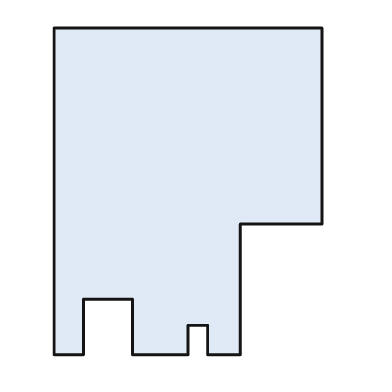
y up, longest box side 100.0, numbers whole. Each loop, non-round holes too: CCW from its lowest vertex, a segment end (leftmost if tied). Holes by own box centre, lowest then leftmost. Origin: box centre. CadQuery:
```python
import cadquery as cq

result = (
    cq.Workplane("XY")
    .moveTo(-41.0, -50.0)
    .lineTo(-32.0, -50.0)
    .lineTo(-32.0, -33.0)
    .lineTo(-17.0, -33.0)
    .lineTo(-17.0, -50.0)
    .lineTo(0.0, -50.0)
    .lineTo(0.0, -41.0)
    .lineTo(6.0, -41.0)
    .lineTo(6.0, -50.0)
    .lineTo(16.0, -50.0)
    .lineTo(16.0, -10.0)
    .lineTo(41.0, -10.0)
    .lineTo(41.0, 50.0)
    .lineTo(-41.0, 50.0)
    .close()
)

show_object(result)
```